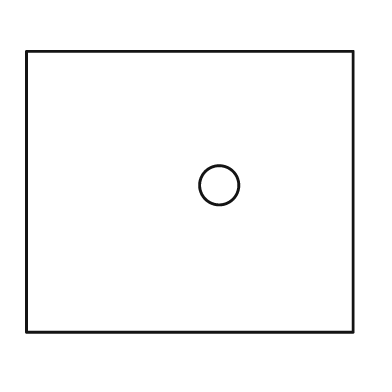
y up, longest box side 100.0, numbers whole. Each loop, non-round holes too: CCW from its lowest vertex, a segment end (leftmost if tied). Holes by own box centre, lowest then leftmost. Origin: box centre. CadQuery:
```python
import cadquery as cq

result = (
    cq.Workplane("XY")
    .moveTo(-50.0, -43.0)
    .lineTo(50.0, -43.0)
    .lineTo(50.0, 43.0)
    .lineTo(-50.0, 43.0)
    .close()
    .moveTo(9.0, 2.0)
    .circle(6.0)
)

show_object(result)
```